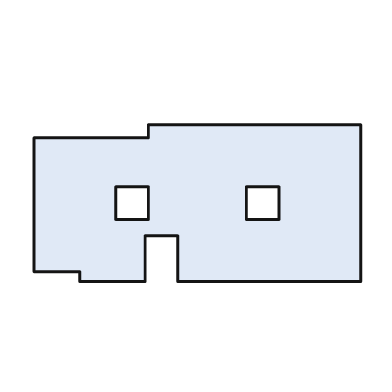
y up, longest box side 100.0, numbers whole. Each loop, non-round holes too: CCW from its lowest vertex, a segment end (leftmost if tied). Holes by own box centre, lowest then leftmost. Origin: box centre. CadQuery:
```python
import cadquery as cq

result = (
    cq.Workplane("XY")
    .moveTo(-36.0, -24.0)
    .lineTo(-16.0, -24.0)
    .lineTo(-16.0, -10.0)
    .lineTo(-6.0, -10.0)
    .lineTo(-6.0, -24.0)
    .lineTo(50.0, -24.0)
    .lineTo(50.0, 24.0)
    .lineTo(-15.0, 24.0)
    .lineTo(-15.0, 20.0)
    .lineTo(-50.0, 20.0)
    .lineTo(-50.0, -21.0)
    .lineTo(-36.0, -21.0)
    .close()
    .moveTo(-25.0, -5.0)
    .lineTo(-15.0, -5.0)
    .lineTo(-15.0, 5.0)
    .lineTo(-25.0, 5.0)
    .close()
    .moveTo(15.0, -5.0)
    .lineTo(25.0, -5.0)
    .lineTo(25.0, 5.0)
    .lineTo(15.0, 5.0)
    .close()
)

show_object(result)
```